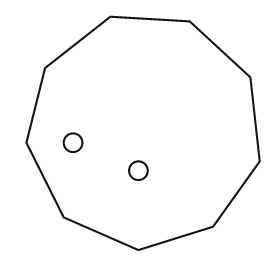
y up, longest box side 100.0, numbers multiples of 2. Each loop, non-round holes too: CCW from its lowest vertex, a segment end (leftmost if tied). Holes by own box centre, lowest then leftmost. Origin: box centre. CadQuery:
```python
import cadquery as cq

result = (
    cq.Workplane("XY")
    .moveTo(-2.0, -50.0)
    .lineTo(30.0, -40.0)
    .lineTo(50.0, -12.0)
    .lineTo(46.0, 24.0)
    .lineTo(20.0, 48.0)
    .lineTo(-14.0, 50.0)
    .lineTo(-42.0, 28.0)
    .lineTo(-50.0, -4.0)
    .lineTo(-34.0, -36.0)
    .close()
    .moveTo(-2.0, -16.0)
    .circle(4.0)
    .moveTo(-30.0, -4.0)
    .circle(4.0)
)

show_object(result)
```